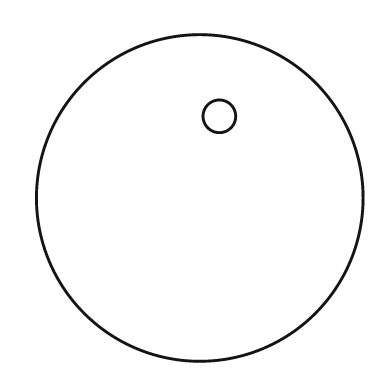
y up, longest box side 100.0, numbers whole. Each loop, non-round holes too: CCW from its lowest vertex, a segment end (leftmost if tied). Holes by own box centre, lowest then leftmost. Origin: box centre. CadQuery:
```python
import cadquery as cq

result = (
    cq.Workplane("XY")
    .moveTo(0.0, 0.0)
    .circle(50.0)
    .moveTo(6.0, 25.0)
    .circle(5.0)
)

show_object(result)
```